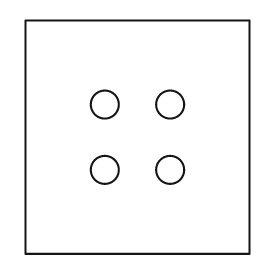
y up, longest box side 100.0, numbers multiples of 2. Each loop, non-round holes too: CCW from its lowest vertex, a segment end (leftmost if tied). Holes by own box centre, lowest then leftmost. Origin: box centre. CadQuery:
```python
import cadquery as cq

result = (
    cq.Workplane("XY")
    .moveTo(-48.0, -50.0)
    .lineTo(48.0, -50.0)
    .lineTo(48.0, 50.0)
    .lineTo(-48.0, 50.0)
    .close()
    .moveTo(-14.0, -14.0)
    .circle(6.0)
    .moveTo(14.0, -14.0)
    .circle(6.0)
    .moveTo(-14.0, 14.0)
    .circle(6.0)
    .moveTo(14.0, 14.0)
    .circle(6.0)
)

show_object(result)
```